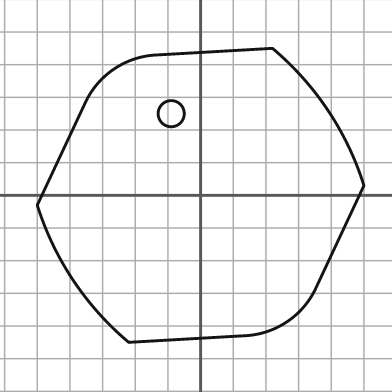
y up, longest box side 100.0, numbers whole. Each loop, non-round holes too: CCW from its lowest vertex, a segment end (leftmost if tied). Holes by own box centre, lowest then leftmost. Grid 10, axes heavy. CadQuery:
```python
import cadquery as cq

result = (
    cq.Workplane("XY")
    .moveTo(-22.0, -45.0)
    .lineTo(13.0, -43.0)
    .threePointArc((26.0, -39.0), (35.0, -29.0))
    .lineTo(50.0, 3.0)
    .threePointArc((39.0, 26.0), (22.0, 45.0))
    .lineTo(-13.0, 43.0)
    .threePointArc((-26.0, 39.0), (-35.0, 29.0))
    .lineTo(-50.0, -3.0)
    .threePointArc((-39.0, -26.0), (-22.0, -45.0))
    .close()
    .moveTo(-9.0, 25.0)
    .circle(4.0)
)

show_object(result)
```